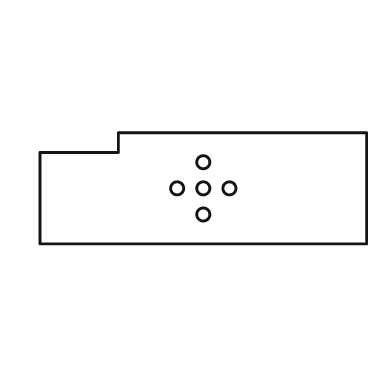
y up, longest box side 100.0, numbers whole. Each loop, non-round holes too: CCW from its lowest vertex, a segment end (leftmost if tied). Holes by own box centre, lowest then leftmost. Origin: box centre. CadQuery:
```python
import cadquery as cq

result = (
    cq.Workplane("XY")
    .moveTo(-50.0, -17.0)
    .lineTo(50.0, -17.0)
    .lineTo(50.0, 17.0)
    .lineTo(-26.0, 17.0)
    .lineTo(-26.0, 11.0)
    .lineTo(-50.0, 11.0)
    .close()
    .moveTo(0.0, -8.0)
    .circle(2.0)
    .moveTo(-8.0, 0.0)
    .circle(2.0)
    .moveTo(0.0, 0.0)
    .circle(2.0)
    .moveTo(8.0, 0.0)
    .circle(2.0)
    .moveTo(0.0, 8.0)
    .circle(2.0)
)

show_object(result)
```